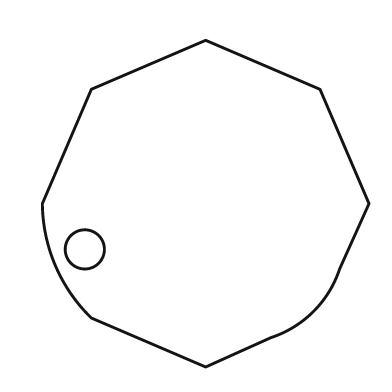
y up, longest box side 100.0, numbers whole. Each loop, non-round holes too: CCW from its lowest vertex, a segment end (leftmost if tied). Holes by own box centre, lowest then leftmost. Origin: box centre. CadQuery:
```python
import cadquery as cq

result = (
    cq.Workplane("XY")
    .moveTo(0.0, -50.0)
    .lineTo(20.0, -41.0)
    .threePointArc((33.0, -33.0), (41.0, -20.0))
    .lineTo(50.0, 0.0)
    .lineTo(35.0, 35.0)
    .lineTo(0.0, 50.0)
    .lineTo(-35.0, 35.0)
    .lineTo(-50.0, 0.0)
    .threePointArc((-46.0, -19.0), (-35.0, -35.0))
    .close()
    .moveTo(-37.0, -14.0)
    .circle(6.0)
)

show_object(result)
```